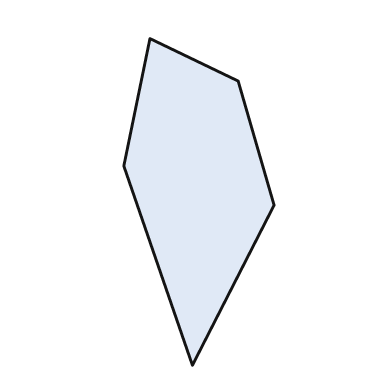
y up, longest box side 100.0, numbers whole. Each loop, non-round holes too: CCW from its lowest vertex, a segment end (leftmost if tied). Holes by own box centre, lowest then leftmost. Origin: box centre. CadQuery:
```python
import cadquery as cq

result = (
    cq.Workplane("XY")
    .moveTo(-2.0, -50.0)
    .lineTo(23.0, -1.0)
    .lineTo(12.0, 37.0)
    .lineTo(-15.0, 50.0)
    .lineTo(-23.0, 11.0)
    .close()
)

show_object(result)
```